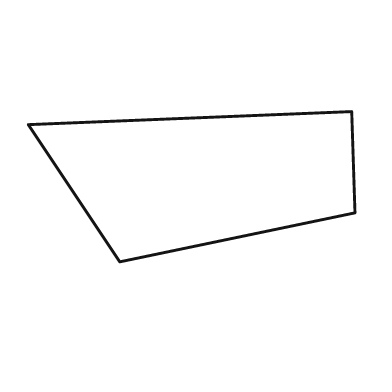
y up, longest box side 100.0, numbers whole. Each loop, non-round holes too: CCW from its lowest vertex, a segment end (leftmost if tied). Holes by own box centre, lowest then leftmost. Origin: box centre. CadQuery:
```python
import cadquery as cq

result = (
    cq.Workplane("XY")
    .moveTo(-22.0, -23.0)
    .lineTo(50.0, -8.0)
    .lineTo(49.0, 23.0)
    .lineTo(-50.0, 19.0)
    .close()
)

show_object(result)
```